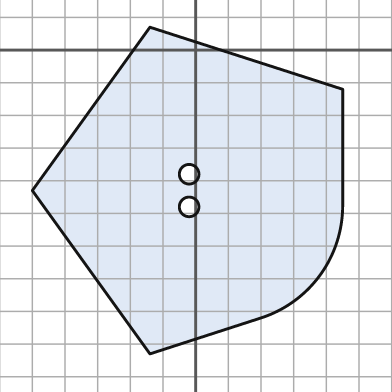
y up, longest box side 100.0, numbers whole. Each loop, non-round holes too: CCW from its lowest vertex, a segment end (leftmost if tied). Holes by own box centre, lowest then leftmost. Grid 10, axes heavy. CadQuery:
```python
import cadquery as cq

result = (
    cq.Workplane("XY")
    .moveTo(-14.0, -93.0)
    .lineTo(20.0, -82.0)
    .threePointArc((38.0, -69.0), (45.0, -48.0))
    .lineTo(45.0, -12.0)
    .lineTo(-14.0, 7.0)
    .lineTo(-50.0, -43.0)
    .close()
    .moveTo(-2.0, -48.0)
    .circle(3.0)
    .moveTo(-2.0, -38.0)
    .circle(3.0)
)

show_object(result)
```